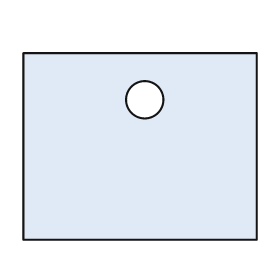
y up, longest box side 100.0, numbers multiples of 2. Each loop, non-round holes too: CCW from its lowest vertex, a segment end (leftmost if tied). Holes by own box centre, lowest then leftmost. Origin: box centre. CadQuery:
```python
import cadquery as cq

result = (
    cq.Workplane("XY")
    .moveTo(-50.0, -40.0)
    .lineTo(50.0, -40.0)
    .lineTo(50.0, 40.0)
    .lineTo(-50.0, 40.0)
    .close()
    .moveTo(2.0, 20.0)
    .circle(8.0)
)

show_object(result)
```